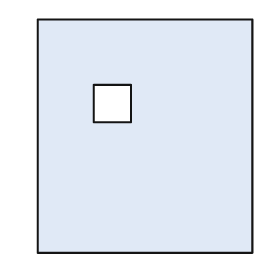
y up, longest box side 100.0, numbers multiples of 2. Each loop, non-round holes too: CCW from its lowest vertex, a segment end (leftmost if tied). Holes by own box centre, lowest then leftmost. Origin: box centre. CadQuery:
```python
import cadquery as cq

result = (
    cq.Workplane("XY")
    .moveTo(-46.0, -50.0)
    .lineTo(46.0, -50.0)
    .lineTo(46.0, 50.0)
    .lineTo(-46.0, 50.0)
    .close()
    .moveTo(-22.0, 6.0)
    .lineTo(-6.0, 6.0)
    .lineTo(-6.0, 22.0)
    .lineTo(-22.0, 22.0)
    .close()
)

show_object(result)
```